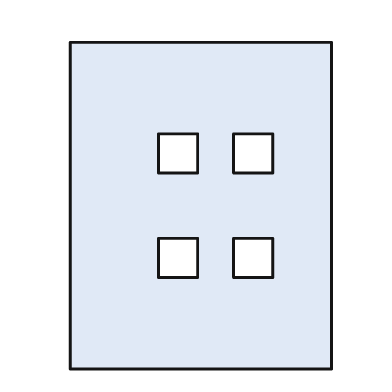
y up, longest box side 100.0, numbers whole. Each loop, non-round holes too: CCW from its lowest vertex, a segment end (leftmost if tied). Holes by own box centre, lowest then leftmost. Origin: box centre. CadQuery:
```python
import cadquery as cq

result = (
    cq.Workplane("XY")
    .moveTo(-40.0, -50.0)
    .lineTo(40.0, -50.0)
    .lineTo(40.0, 50.0)
    .lineTo(-40.0, 50.0)
    .close()
    .moveTo(-13.0, -22.0)
    .lineTo(-1.0, -22.0)
    .lineTo(-1.0, -10.0)
    .lineTo(-13.0, -10.0)
    .close()
    .moveTo(10.0, -22.0)
    .lineTo(22.0, -22.0)
    .lineTo(22.0, -10.0)
    .lineTo(10.0, -10.0)
    .close()
    .moveTo(-13.0, 10.0)
    .lineTo(-1.0, 10.0)
    .lineTo(-1.0, 22.0)
    .lineTo(-13.0, 22.0)
    .close()
    .moveTo(10.0, 10.0)
    .lineTo(22.0, 10.0)
    .lineTo(22.0, 22.0)
    .lineTo(10.0, 22.0)
    .close()
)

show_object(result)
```